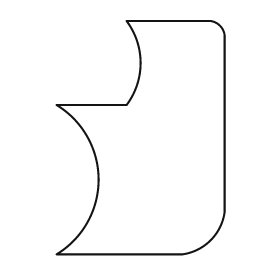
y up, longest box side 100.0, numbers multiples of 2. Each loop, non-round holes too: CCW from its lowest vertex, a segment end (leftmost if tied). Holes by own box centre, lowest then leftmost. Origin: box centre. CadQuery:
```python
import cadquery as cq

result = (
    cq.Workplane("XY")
    .moveTo(-36.0, -50.0)
    .lineTo(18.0, -50.0)
    .threePointArc((30.0, -44.0), (36.0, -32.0))
    .lineTo(36.0, 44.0)
    .threePointArc((34.0, 48.0), (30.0, 50.0))
    .lineTo(-6.0, 50.0)
    .threePointArc((0.0, 32.0), (-6.0, 14.0))
    .lineTo(-36.0, 14.0)
    .threePointArc((-18.0, -18.0), (-36.0, -50.0))
    .close()
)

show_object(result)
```